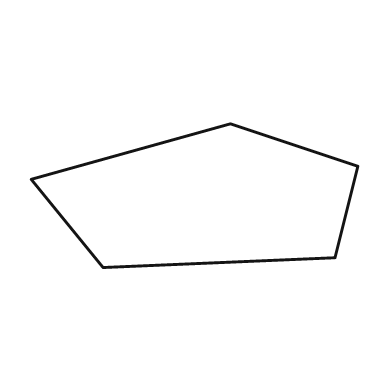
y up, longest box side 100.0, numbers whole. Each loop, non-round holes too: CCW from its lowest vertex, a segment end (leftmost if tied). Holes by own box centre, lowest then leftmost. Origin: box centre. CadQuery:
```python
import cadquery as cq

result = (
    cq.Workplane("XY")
    .moveTo(-28.0, -22.0)
    .lineTo(43.0, -19.0)
    .lineTo(50.0, 9.0)
    .lineTo(11.0, 22.0)
    .lineTo(-50.0, 5.0)
    .close()
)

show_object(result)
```